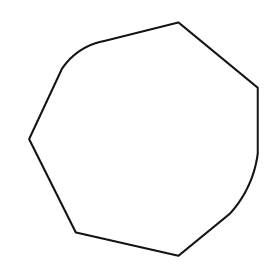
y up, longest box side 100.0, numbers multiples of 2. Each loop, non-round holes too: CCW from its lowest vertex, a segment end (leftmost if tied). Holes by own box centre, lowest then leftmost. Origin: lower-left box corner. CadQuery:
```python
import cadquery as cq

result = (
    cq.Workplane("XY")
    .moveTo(64.0, 0.0)
    .lineTo(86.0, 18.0)
    .threePointArc((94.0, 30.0), (98.0, 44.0))
    .lineTo(98.0, 72.0)
    .lineTo(64.0, 100.0)
    .lineTo(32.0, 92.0)
    .threePointArc((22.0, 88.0), (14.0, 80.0))
    .lineTo(0.0, 50.0)
    .lineTo(20.0, 10.0)
    .close()
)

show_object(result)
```